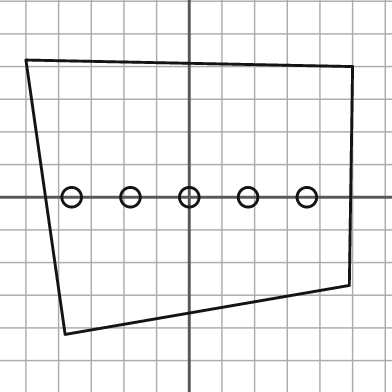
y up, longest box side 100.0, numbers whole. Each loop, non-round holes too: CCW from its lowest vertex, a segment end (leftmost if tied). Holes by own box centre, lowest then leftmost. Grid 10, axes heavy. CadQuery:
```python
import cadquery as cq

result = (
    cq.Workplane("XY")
    .moveTo(-38.0, -42.0)
    .lineTo(49.0, -27.0)
    .lineTo(50.0, 40.0)
    .lineTo(-50.0, 42.0)
    .close()
    .moveTo(-36.0, 0.0)
    .circle(3.0)
    .moveTo(-18.0, 0.0)
    .circle(3.0)
    .moveTo(0.0, 0.0)
    .circle(3.0)
    .moveTo(18.0, 0.0)
    .circle(3.0)
    .moveTo(36.0, 0.0)
    .circle(3.0)
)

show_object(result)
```